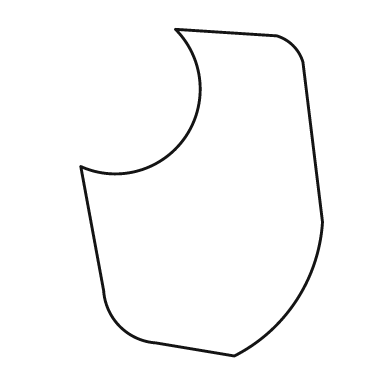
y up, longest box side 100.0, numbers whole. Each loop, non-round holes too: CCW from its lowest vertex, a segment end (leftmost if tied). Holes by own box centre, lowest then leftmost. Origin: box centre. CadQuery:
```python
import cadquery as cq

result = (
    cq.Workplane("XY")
    .moveTo(10.0, -50.0)
    .threePointArc((29.0, -33.0), (37.0, -9.0))
    .lineTo(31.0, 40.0)
    .threePointArc((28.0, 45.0), (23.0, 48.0))
    .lineTo(-8.0, 50.0)
    .threePointArc((-5.0, 17.0), (-37.0, 8.0))
    .lineTo(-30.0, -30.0)
    .threePointArc((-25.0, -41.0), (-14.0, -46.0))
    .close()
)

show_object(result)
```